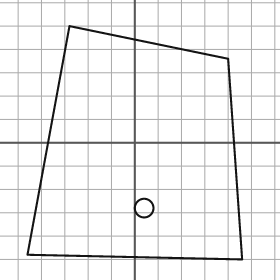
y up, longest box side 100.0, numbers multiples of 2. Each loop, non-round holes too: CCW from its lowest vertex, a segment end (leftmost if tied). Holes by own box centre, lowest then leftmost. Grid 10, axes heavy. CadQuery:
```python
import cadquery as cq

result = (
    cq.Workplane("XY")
    .moveTo(46.0, -50.0)
    .lineTo(40.0, 36.0)
    .lineTo(-28.0, 50.0)
    .lineTo(-46.0, -48.0)
    .close()
    .moveTo(4.0, -28.0)
    .circle(4.0)
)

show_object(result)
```